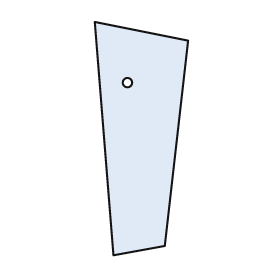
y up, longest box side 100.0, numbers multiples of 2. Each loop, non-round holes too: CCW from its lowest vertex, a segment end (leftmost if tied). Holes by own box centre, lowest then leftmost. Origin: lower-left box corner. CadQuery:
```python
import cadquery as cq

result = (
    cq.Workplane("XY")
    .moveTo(8.0, 0.0)
    .lineTo(30.0, 4.0)
    .lineTo(40.0, 92.0)
    .lineTo(0.0, 100.0)
    .close()
    .moveTo(14.0, 74.0)
    .circle(2.0)
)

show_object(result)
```